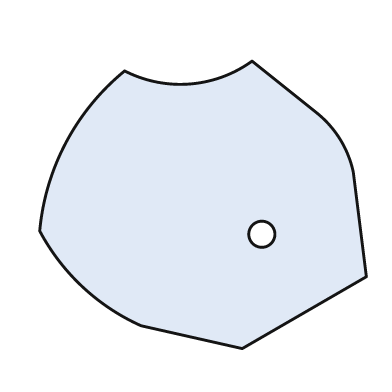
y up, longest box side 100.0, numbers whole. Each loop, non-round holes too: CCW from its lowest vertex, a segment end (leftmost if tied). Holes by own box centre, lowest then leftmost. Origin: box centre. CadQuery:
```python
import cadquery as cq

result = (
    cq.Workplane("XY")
    .moveTo(12.0, -44.0)
    .lineTo(50.0, -22.0)
    .lineTo(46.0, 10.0)
    .threePointArc((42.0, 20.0), (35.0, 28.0))
    .lineTo(15.0, 44.0)
    .threePointArc((-4.0, 37.0), (-24.0, 41.0))
    .threePointArc((-42.0, 19.0), (-50.0, -8.0))
    .threePointArc((-37.0, -25.0), (-19.0, -37.0))
    .close()
    .moveTo(18.0, -9.0)
    .circle(4.0)
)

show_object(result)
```